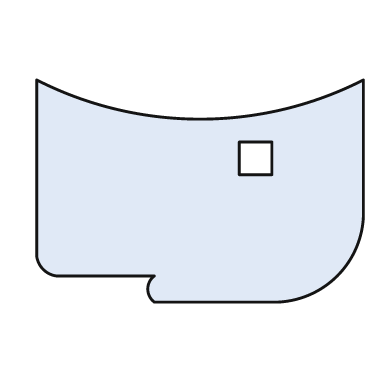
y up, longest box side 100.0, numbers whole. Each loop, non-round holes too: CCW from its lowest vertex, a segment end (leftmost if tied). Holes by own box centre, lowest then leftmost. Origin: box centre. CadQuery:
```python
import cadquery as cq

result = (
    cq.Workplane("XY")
    .moveTo(-14.0, -34.0)
    .lineTo(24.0, -34.0)
    .threePointArc((42.0, -26.0), (50.0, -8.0))
    .lineTo(50.0, 34.0)
    .threePointArc((0.0, 22.0), (-50.0, 34.0))
    .lineTo(-50.0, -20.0)
    .threePointArc((-48.0, -24.0), (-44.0, -26.0))
    .lineTo(-14.0, -26.0)
    .threePointArc((-16.0, -30.0), (-14.0, -34.0))
    .close()
    .moveTo(12.0, 5.0)
    .lineTo(22.0, 5.0)
    .lineTo(22.0, 15.0)
    .lineTo(12.0, 15.0)
    .close()
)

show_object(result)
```